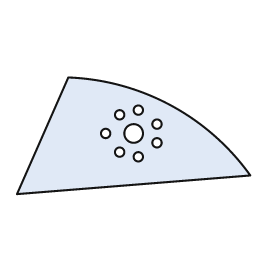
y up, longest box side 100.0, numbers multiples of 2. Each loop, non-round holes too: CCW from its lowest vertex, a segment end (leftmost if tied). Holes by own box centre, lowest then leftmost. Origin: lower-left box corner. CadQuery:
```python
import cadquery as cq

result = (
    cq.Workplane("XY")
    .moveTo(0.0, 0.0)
    .lineTo(100.0, 8.0)
    .threePointArc((66.0, 38.0), (22.0, 50.0))
    .close()
    .moveTo(52.0, 16.0)
    .circle(2.0)
    .moveTo(44.0, 18.0)
    .circle(2.0)
    .moveTo(60.0, 22.0)
    .circle(2.0)
    .moveTo(38.0, 26.0)
    .circle(2.0)
    .moveTo(50.0, 26.0)
    .circle(4.0)
    .moveTo(60.0, 30.0)
    .circle(2.0)
    .moveTo(44.0, 34.0)
    .circle(2.0)
    .moveTo(52.0, 36.0)
    .circle(2.0)
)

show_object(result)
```